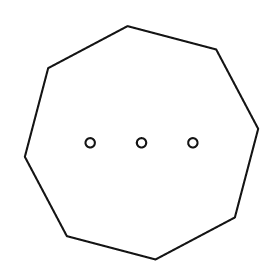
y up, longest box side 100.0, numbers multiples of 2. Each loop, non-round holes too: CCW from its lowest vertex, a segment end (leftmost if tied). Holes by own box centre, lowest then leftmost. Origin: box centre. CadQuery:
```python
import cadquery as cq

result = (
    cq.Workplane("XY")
    .moveTo(6.0, -50.0)
    .lineTo(40.0, -32.0)
    .lineTo(50.0, 6.0)
    .lineTo(32.0, 40.0)
    .lineTo(-6.0, 50.0)
    .lineTo(-40.0, 32.0)
    .lineTo(-50.0, -6.0)
    .lineTo(-32.0, -40.0)
    .close()
    .moveTo(-22.0, 0.0)
    .circle(2.0)
    .moveTo(0.0, 0.0)
    .circle(2.0)
    .moveTo(22.0, 0.0)
    .circle(2.0)
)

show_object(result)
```